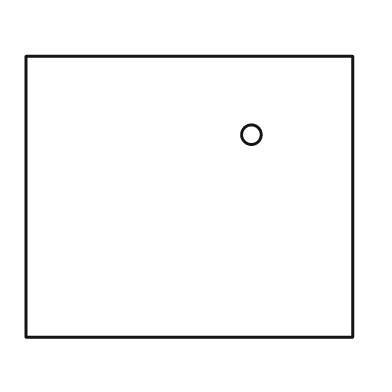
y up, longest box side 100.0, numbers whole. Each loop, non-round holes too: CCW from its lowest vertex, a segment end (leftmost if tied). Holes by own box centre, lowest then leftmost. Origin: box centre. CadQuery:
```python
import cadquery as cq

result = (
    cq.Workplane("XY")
    .moveTo(-50.0, -43.0)
    .lineTo(50.0, -43.0)
    .lineTo(50.0, 43.0)
    .lineTo(-50.0, 43.0)
    .close()
    .moveTo(19.0, 19.0)
    .circle(3.0)
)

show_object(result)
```